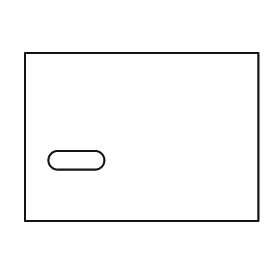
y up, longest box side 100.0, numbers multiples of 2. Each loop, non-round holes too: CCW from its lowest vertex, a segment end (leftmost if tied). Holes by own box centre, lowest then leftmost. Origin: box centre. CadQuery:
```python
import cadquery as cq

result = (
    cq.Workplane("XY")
    .moveTo(-50.0, -36.0)
    .lineTo(50.0, -36.0)
    .lineTo(50.0, 36.0)
    .lineTo(-50.0, 36.0)
    .close()
    .moveTo(-36.0, -14.0)
    .lineTo(-20.0, -14.0)
    .threePointArc((-16.0, -10.0), (-20.0, -6.0))
    .lineTo(-36.0, -6.0)
    .threePointArc((-40.0, -10.0), (-36.0, -14.0))
    .close()
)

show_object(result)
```